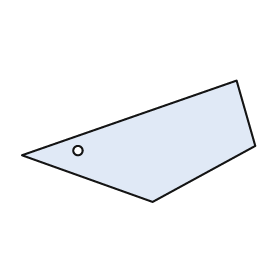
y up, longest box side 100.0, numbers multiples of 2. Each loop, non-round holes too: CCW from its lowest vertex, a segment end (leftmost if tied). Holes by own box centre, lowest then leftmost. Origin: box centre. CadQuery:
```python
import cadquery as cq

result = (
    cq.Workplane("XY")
    .moveTo(6.0, -26.0)
    .lineTo(50.0, -2.0)
    .lineTo(42.0, 26.0)
    .lineTo(-50.0, -6.0)
    .close()
    .moveTo(-26.0, -4.0)
    .circle(2.0)
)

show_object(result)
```